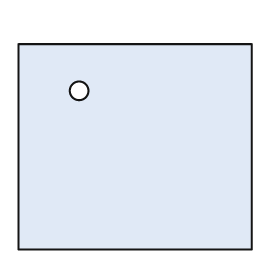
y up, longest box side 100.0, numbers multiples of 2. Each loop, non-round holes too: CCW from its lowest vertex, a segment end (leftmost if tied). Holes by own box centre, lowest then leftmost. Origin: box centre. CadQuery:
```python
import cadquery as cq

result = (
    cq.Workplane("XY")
    .moveTo(-50.0, -44.0)
    .lineTo(50.0, -44.0)
    .lineTo(50.0, 44.0)
    .lineTo(-50.0, 44.0)
    .close()
    .moveTo(-24.0, 24.0)
    .circle(4.0)
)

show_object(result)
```